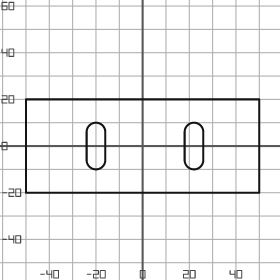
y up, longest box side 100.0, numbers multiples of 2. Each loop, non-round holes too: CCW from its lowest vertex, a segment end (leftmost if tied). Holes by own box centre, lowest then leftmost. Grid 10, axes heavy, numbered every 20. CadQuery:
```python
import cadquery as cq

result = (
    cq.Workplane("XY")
    .moveTo(-50.0, -20.0)
    .lineTo(50.0, -20.0)
    .lineTo(50.0, 20.0)
    .lineTo(-50.0, 20.0)
    .close()
    .moveTo(-24.0, -6.0)
    .threePointArc((-20.0, -10.0), (-16.0, -6.0))
    .lineTo(-16.0, 6.0)
    .threePointArc((-20.0, 10.0), (-24.0, 6.0))
    .close()
    .moveTo(18.0, -6.0)
    .threePointArc((22.0, -10.0), (26.0, -6.0))
    .lineTo(26.0, 6.0)
    .threePointArc((22.0, 10.0), (18.0, 6.0))
    .close()
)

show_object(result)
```